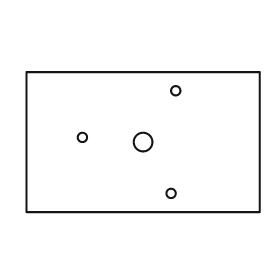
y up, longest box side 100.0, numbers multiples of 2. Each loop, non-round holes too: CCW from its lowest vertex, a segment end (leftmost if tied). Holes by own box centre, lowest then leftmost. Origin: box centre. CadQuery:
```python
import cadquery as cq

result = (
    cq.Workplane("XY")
    .moveTo(-50.0, -30.0)
    .lineTo(50.0, -30.0)
    .lineTo(50.0, 30.0)
    .lineTo(-50.0, 30.0)
    .close()
    .moveTo(12.0, -22.0)
    .circle(2.0)
    .moveTo(0.0, 0.0)
    .circle(4.0)
    .moveTo(-26.0, 2.0)
    .circle(2.0)
    .moveTo(14.0, 22.0)
    .circle(2.0)
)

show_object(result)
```